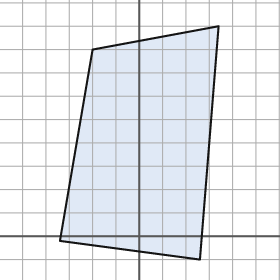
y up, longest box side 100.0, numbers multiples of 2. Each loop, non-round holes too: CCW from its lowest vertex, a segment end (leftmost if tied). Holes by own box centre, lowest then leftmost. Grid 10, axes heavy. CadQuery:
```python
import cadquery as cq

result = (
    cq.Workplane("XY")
    .moveTo(26.0, -10.0)
    .lineTo(34.0, 90.0)
    .lineTo(-20.0, 80.0)
    .lineTo(-34.0, -2.0)
    .close()
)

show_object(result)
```